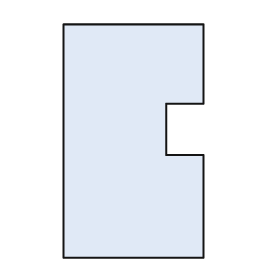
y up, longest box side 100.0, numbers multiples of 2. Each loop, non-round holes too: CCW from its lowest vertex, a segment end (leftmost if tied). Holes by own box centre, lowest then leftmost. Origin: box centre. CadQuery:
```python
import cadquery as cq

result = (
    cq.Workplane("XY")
    .moveTo(-30.0, -50.0)
    .lineTo(30.0, -50.0)
    .lineTo(30.0, -6.0)
    .lineTo(14.0, -6.0)
    .lineTo(14.0, 16.0)
    .lineTo(30.0, 16.0)
    .lineTo(30.0, 50.0)
    .lineTo(-30.0, 50.0)
    .close()
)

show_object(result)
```